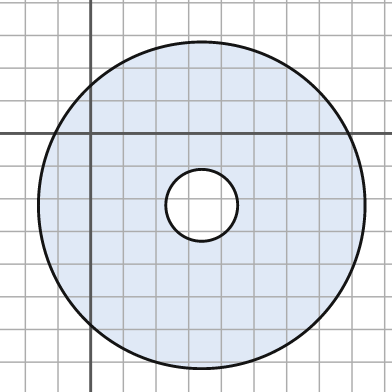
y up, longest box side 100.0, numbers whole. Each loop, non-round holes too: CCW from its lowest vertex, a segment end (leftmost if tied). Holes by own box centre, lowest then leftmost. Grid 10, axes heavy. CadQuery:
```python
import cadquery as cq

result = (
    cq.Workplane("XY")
    .moveTo(34.0, -22.0)
    .circle(50.0)
    .moveTo(34.0, -22.0)
    .circle(11.0)
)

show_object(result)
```